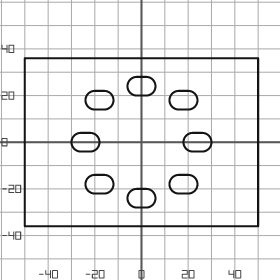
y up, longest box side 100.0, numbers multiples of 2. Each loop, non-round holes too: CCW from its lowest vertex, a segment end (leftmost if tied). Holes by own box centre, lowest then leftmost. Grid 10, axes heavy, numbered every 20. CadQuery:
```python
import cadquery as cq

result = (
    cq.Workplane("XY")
    .moveTo(-50.0, -36.0)
    .lineTo(50.0, -36.0)
    .lineTo(50.0, 36.0)
    .lineTo(-50.0, 36.0)
    .close()
    .moveTo(-2.0, -28.0)
    .lineTo(2.0, -28.0)
    .threePointArc((6.0, -24.0), (2.0, -20.0))
    .lineTo(-2.0, -20.0)
    .threePointArc((-6.0, -24.0), (-2.0, -28.0))
    .close()
    .moveTo(-20.0, -22.0)
    .lineTo(-16.0, -22.0)
    .threePointArc((-12.0, -18.0), (-16.0, -14.0))
    .lineTo(-20.0, -14.0)
    .threePointArc((-24.0, -18.0), (-20.0, -22.0))
    .close()
    .moveTo(16.0, -22.0)
    .lineTo(20.0, -22.0)
    .threePointArc((24.0, -18.0), (20.0, -14.0))
    .lineTo(16.0, -14.0)
    .threePointArc((12.0, -18.0), (16.0, -22.0))
    .close()
    .moveTo(-26.0, -4.0)
    .lineTo(-22.0, -4.0)
    .threePointArc((-18.0, 0.0), (-22.0, 4.0))
    .lineTo(-26.0, 4.0)
    .threePointArc((-30.0, 0.0), (-26.0, -4.0))
    .close()
    .moveTo(22.0, -4.0)
    .lineTo(26.0, -4.0)
    .threePointArc((30.0, 0.0), (26.0, 4.0))
    .lineTo(22.0, 4.0)
    .threePointArc((18.0, 0.0), (22.0, -4.0))
    .close()
    .moveTo(-20.0, 14.0)
    .lineTo(-16.0, 14.0)
    .threePointArc((-12.0, 18.0), (-16.0, 22.0))
    .lineTo(-20.0, 22.0)
    .threePointArc((-24.0, 18.0), (-20.0, 14.0))
    .close()
    .moveTo(16.0, 14.0)
    .lineTo(20.0, 14.0)
    .threePointArc((24.0, 18.0), (20.0, 22.0))
    .lineTo(16.0, 22.0)
    .threePointArc((12.0, 18.0), (16.0, 14.0))
    .close()
    .moveTo(-2.0, 20.0)
    .lineTo(2.0, 20.0)
    .threePointArc((6.0, 24.0), (2.0, 28.0))
    .lineTo(-2.0, 28.0)
    .threePointArc((-6.0, 24.0), (-2.0, 20.0))
    .close()
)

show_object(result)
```